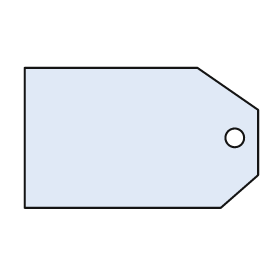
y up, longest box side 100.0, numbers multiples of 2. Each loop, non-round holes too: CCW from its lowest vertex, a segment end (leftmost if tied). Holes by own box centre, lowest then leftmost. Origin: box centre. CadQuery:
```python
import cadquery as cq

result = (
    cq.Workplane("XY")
    .moveTo(-50.0, -30.0)
    .lineTo(34.0, -30.0)
    .lineTo(50.0, -16.0)
    .lineTo(50.0, 12.0)
    .lineTo(24.0, 30.0)
    .lineTo(-50.0, 30.0)
    .close()
    .moveTo(40.0, 0.0)
    .circle(4.0)
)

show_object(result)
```